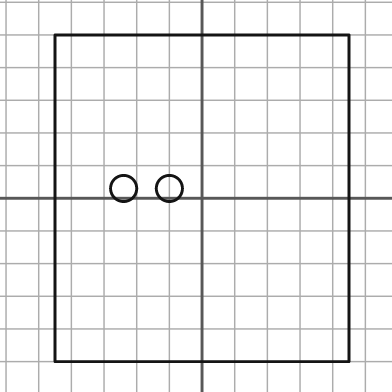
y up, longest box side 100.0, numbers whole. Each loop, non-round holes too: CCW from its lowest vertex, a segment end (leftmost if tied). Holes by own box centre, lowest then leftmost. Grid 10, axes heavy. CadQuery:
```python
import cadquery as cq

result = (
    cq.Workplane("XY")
    .moveTo(-45.0, -50.0)
    .lineTo(45.0, -50.0)
    .lineTo(45.0, 50.0)
    .lineTo(-45.0, 50.0)
    .close()
    .moveTo(-24.0, 3.0)
    .circle(4.0)
    .moveTo(-10.0, 3.0)
    .circle(4.0)
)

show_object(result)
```